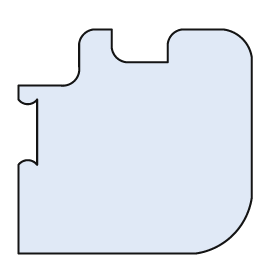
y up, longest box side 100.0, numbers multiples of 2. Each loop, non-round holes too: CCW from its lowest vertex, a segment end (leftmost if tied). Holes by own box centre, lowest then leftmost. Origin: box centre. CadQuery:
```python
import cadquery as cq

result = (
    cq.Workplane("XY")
    .moveTo(-50.0, -48.0)
    .lineTo(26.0, -48.0)
    .threePointArc((42.0, -40.0), (50.0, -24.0))
    .lineTo(50.0, 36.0)
    .threePointArc((46.0, 44.0), (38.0, 48.0))
    .lineTo(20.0, 48.0)
    .threePointArc((16.0, 46.0), (14.0, 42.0))
    .lineTo(14.0, 34.0)
    .lineTo(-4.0, 34.0)
    .threePointArc((-8.0, 36.0), (-10.0, 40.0))
    .lineTo(-10.0, 48.0)
    .lineTo(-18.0, 48.0)
    .threePointArc((-22.0, 46.0), (-24.0, 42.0))
    .lineTo(-24.0, 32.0)
    .threePointArc((-26.0, 26.0), (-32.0, 24.0))
    .lineTo(-50.0, 24.0)
    .lineTo(-50.0, 18.0)
    .threePointArc((-46.0, 16.0), (-42.0, 18.0))
    .lineTo(-42.0, -10.0)
    .threePointArc((-46.0, -8.0), (-50.0, -10.0))
    .close()
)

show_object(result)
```